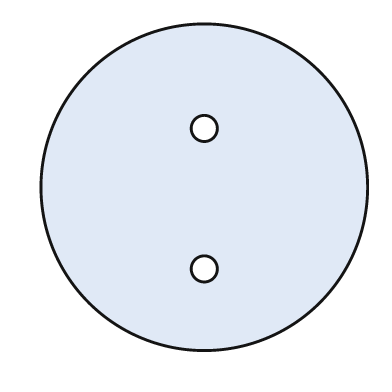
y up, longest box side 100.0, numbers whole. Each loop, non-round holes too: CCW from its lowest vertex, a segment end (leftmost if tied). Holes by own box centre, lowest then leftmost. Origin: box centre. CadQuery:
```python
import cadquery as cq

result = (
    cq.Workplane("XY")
    .moveTo(0.0, 0.0)
    .circle(50.0)
    .moveTo(0.0, -25.0)
    .circle(4.0)
    .moveTo(0.0, 18.0)
    .circle(4.0)
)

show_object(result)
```